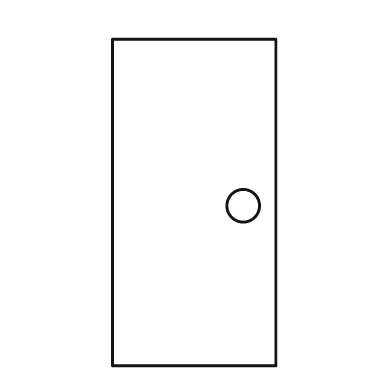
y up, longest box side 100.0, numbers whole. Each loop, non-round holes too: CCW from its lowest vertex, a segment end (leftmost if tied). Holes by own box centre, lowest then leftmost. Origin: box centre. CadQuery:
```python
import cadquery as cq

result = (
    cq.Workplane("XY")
    .moveTo(-25.0, -50.0)
    .lineTo(25.0, -50.0)
    .lineTo(25.0, 50.0)
    .lineTo(-25.0, 50.0)
    .close()
    .moveTo(15.0, -1.0)
    .circle(5.0)
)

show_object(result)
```